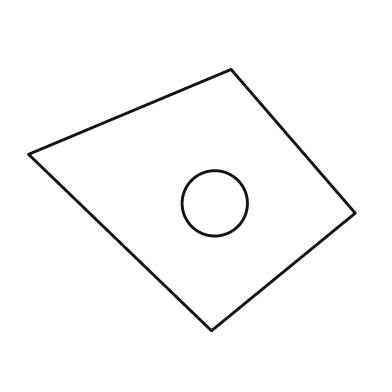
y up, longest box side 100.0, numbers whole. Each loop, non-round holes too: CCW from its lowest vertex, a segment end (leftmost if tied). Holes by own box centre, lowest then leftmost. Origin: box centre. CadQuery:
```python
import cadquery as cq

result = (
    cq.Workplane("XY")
    .moveTo(6.0, -40.0)
    .lineTo(50.0, -4.0)
    .lineTo(12.0, 40.0)
    .lineTo(-50.0, 14.0)
    .close()
    .moveTo(7.0, -1.0)
    .circle(10.0)
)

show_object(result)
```